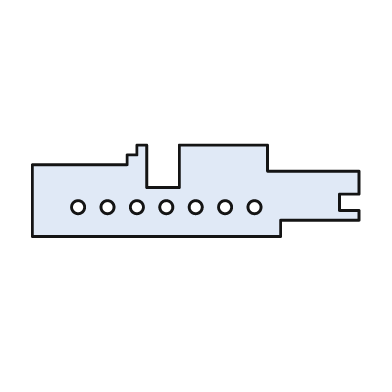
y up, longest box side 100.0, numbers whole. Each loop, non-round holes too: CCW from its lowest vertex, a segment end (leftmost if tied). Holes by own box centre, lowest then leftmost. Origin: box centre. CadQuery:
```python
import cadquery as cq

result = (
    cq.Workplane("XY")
    .moveTo(-50.0, -14.0)
    .lineTo(26.0, -14.0)
    .lineTo(26.0, -9.0)
    .lineTo(50.0, -9.0)
    .lineTo(50.0, -6.0)
    .lineTo(44.0, -6.0)
    .lineTo(44.0, -1.0)
    .lineTo(50.0, -1.0)
    .lineTo(50.0, 6.0)
    .lineTo(22.0, 6.0)
    .lineTo(22.0, 14.0)
    .lineTo(-5.0, 14.0)
    .lineTo(-5.0, 1.0)
    .lineTo(-15.0, 1.0)
    .lineTo(-15.0, 14.0)
    .lineTo(-18.0, 14.0)
    .lineTo(-18.0, 11.0)
    .lineTo(-21.0, 11.0)
    .lineTo(-21.0, 8.0)
    .lineTo(-50.0, 8.0)
    .close()
    .moveTo(-36.0, -5.0)
    .circle(2.0)
    .moveTo(-27.0, -5.0)
    .circle(2.0)
    .moveTo(-18.0, -5.0)
    .circle(2.0)
    .moveTo(-9.0, -5.0)
    .circle(2.0)
    .moveTo(0.0, -5.0)
    .circle(2.0)
    .moveTo(9.0, -5.0)
    .circle(2.0)
    .moveTo(18.0, -5.0)
    .circle(2.0)
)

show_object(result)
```